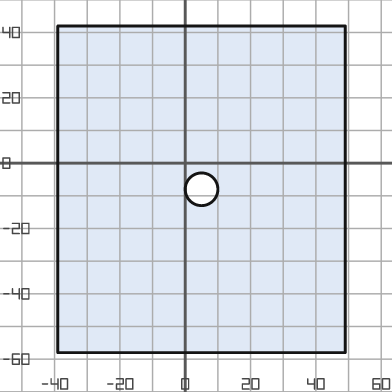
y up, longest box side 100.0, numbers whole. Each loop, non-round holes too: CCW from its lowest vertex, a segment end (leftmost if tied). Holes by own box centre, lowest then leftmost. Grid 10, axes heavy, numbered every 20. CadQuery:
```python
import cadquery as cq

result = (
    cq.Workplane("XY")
    .moveTo(-39.0, -58.0)
    .lineTo(49.0, -58.0)
    .lineTo(49.0, 42.0)
    .lineTo(-39.0, 42.0)
    .close()
    .moveTo(5.0, -8.0)
    .circle(5.0)
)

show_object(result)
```